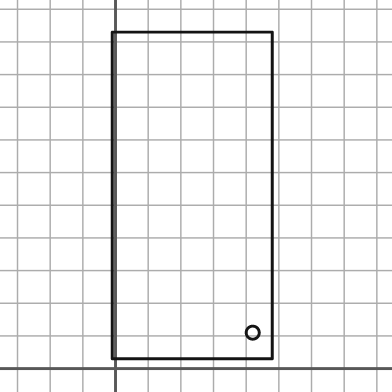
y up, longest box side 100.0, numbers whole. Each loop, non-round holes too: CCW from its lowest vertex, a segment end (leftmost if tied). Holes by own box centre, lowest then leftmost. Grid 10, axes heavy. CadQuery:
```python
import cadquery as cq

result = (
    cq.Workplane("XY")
    .moveTo(-1.0, 3.0)
    .lineTo(48.0, 3.0)
    .lineTo(48.0, 103.0)
    .lineTo(-1.0, 103.0)
    .close()
    .moveTo(42.0, 11.0)
    .circle(2.0)
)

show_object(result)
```